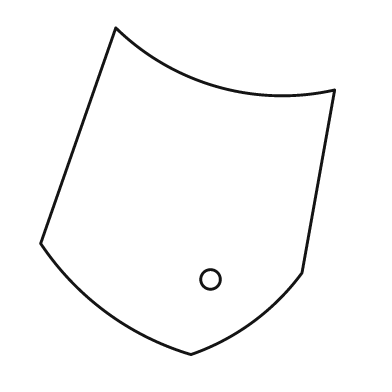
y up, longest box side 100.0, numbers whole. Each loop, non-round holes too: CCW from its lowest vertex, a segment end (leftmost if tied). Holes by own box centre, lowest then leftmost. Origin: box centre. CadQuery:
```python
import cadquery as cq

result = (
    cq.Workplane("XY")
    .moveTo(1.0, -50.0)
    .threePointArc((20.0, -40.0), (35.0, -25.0))
    .lineTo(45.0, 31.0)
    .threePointArc((9.0, 32.0), (-22.0, 50.0))
    .lineTo(-45.0, -16.0)
    .threePointArc((-25.0, -37.0), (1.0, -50.0))
    .close()
    .moveTo(7.0, -27.0)
    .circle(3.0)
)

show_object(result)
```